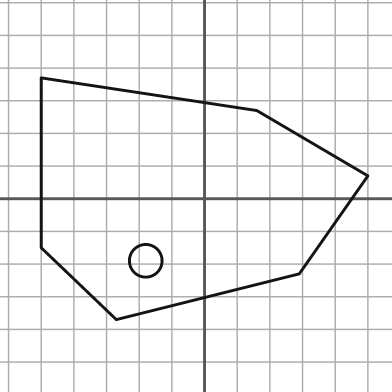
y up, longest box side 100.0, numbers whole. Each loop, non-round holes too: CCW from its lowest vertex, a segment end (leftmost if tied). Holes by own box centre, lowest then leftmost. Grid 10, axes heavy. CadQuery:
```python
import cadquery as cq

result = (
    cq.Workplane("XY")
    .moveTo(-27.0, -37.0)
    .lineTo(29.0, -23.0)
    .lineTo(50.0, 7.0)
    .lineTo(16.0, 27.0)
    .lineTo(-50.0, 37.0)
    .lineTo(-50.0, -15.0)
    .close()
    .moveTo(-18.0, -19.0)
    .circle(5.0)
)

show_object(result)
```